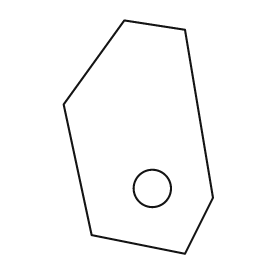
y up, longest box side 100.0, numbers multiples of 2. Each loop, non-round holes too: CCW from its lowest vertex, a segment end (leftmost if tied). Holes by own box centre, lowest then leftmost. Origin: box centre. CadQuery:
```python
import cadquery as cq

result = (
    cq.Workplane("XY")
    .moveTo(20.0, -50.0)
    .lineTo(32.0, -26.0)
    .lineTo(20.0, 46.0)
    .lineTo(-6.0, 50.0)
    .lineTo(-32.0, 14.0)
    .lineTo(-20.0, -42.0)
    .close()
    .moveTo(6.0, -22.0)
    .circle(8.0)
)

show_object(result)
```